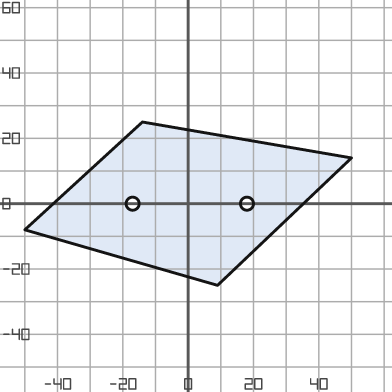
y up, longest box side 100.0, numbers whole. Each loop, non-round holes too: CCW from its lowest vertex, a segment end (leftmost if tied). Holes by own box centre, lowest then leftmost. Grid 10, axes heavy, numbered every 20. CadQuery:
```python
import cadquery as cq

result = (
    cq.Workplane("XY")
    .moveTo(9.0, -25.0)
    .lineTo(50.0, 14.0)
    .lineTo(-14.0, 25.0)
    .lineTo(-50.0, -8.0)
    .close()
    .moveTo(-17.0, 0.0)
    .circle(2.0)
    .moveTo(18.0, 0.0)
    .circle(2.0)
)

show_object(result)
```